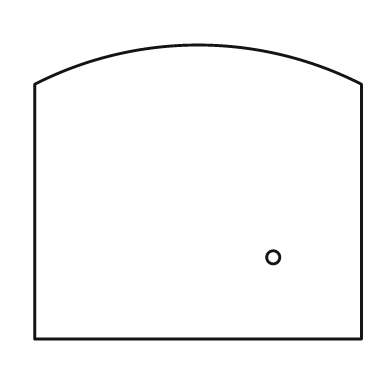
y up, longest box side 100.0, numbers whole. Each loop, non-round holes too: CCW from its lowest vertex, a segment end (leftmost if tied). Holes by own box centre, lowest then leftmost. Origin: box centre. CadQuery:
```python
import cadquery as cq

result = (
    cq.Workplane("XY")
    .moveTo(-50.0, -45.0)
    .lineTo(50.0, -45.0)
    .lineTo(50.0, 33.0)
    .threePointArc((0.0, 45.0), (-50.0, 33.0))
    .close()
    .moveTo(23.0, -20.0)
    .circle(2.0)
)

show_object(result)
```